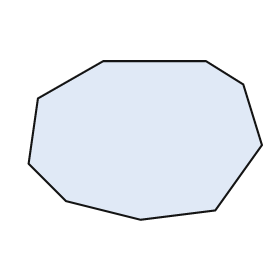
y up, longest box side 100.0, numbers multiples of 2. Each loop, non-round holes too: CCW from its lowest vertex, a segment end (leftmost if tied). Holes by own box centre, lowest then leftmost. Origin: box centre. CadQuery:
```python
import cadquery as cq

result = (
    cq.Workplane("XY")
    .moveTo(-2.0, -34.0)
    .lineTo(30.0, -30.0)
    .lineTo(50.0, -2.0)
    .lineTo(42.0, 24.0)
    .lineTo(26.0, 34.0)
    .lineTo(-18.0, 34.0)
    .lineTo(-46.0, 18.0)
    .lineTo(-50.0, -10.0)
    .lineTo(-34.0, -26.0)
    .close()
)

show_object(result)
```